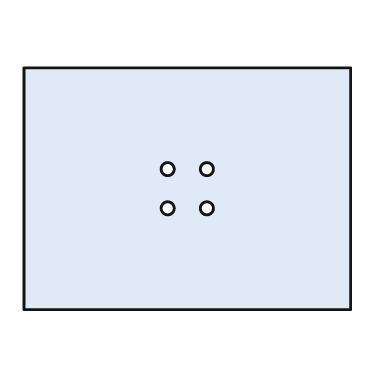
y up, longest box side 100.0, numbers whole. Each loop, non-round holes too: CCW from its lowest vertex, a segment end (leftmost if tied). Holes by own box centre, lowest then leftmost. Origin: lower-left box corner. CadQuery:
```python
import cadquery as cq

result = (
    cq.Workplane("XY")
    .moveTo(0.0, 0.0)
    .lineTo(100.0, 0.0)
    .lineTo(100.0, 74.0)
    .lineTo(0.0, 74.0)
    .close()
    .moveTo(44.0, 31.0)
    .circle(2.0)
    .moveTo(56.0, 31.0)
    .circle(2.0)
    .moveTo(44.0, 43.0)
    .circle(2.0)
    .moveTo(56.0, 43.0)
    .circle(2.0)
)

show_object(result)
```